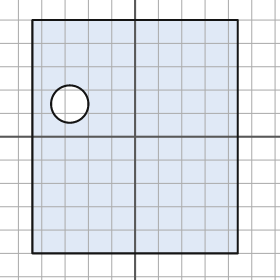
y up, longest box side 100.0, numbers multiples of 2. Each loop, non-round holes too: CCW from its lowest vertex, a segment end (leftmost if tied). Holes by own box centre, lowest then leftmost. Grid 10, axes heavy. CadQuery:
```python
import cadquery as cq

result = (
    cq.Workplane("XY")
    .moveTo(-44.0, -50.0)
    .lineTo(44.0, -50.0)
    .lineTo(44.0, 50.0)
    .lineTo(-44.0, 50.0)
    .close()
    .moveTo(-28.0, 14.0)
    .circle(8.0)
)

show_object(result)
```